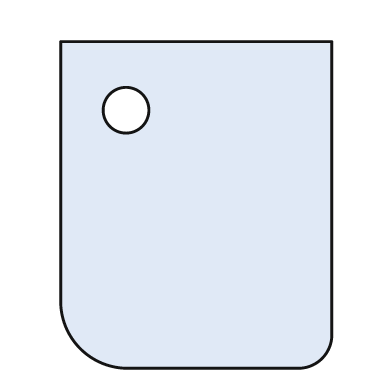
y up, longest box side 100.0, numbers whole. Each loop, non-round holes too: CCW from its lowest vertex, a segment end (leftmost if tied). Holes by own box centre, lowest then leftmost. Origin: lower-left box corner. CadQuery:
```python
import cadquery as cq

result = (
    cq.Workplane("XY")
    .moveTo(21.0, 0.0)
    .lineTo(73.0, 0.0)
    .threePointArc((80.0, 3.0), (83.0, 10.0))
    .lineTo(83.0, 100.0)
    .lineTo(0.0, 100.0)
    .lineTo(0.0, 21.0)
    .threePointArc((6.0, 6.0), (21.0, 0.0))
    .close()
    .moveTo(20.0, 79.0)
    .circle(7.0)
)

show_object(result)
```